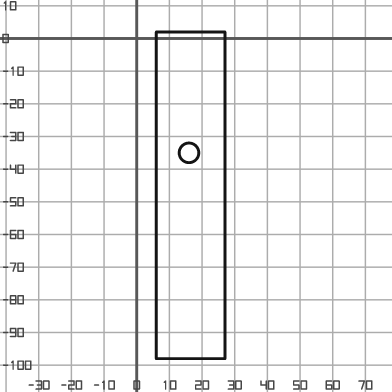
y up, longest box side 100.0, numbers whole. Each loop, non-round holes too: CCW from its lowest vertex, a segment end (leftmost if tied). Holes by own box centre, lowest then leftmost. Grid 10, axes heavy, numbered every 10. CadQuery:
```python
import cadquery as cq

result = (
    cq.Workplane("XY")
    .moveTo(6.0, -98.0)
    .lineTo(27.0, -98.0)
    .lineTo(27.0, 2.0)
    .lineTo(6.0, 2.0)
    .close()
    .moveTo(16.0, -35.0)
    .circle(3.0)
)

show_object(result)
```